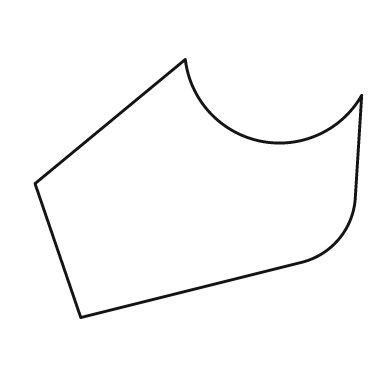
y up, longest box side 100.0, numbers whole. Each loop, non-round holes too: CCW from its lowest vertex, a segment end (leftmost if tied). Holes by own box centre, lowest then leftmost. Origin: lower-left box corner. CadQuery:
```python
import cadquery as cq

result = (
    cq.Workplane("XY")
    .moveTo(14.0, 0.0)
    .lineTo(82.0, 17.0)
    .threePointArc((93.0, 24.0), (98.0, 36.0))
    .lineTo(100.0, 68.0)
    .threePointArc((69.0, 54.0), (46.0, 79.0))
    .lineTo(0.0, 41.0)
    .close()
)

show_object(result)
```